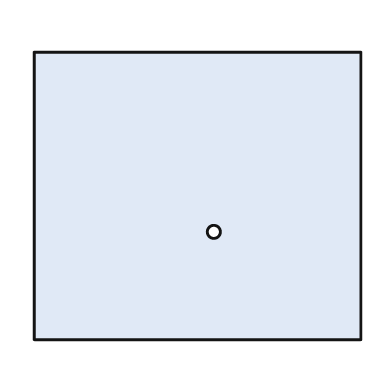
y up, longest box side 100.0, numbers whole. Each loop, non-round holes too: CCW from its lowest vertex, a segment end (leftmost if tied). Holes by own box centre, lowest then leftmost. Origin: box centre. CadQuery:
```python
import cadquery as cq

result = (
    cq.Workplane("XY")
    .moveTo(-50.0, -44.0)
    .lineTo(50.0, -44.0)
    .lineTo(50.0, 44.0)
    .lineTo(-50.0, 44.0)
    .close()
    .moveTo(5.0, -11.0)
    .circle(2.0)
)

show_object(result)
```